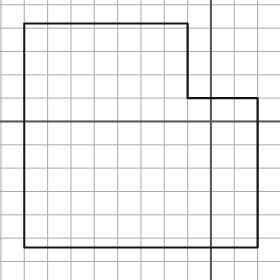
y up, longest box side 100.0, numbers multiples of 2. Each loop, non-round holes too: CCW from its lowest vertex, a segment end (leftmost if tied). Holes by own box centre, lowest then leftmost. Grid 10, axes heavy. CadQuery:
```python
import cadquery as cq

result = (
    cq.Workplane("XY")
    .moveTo(-80.0, -54.0)
    .lineTo(20.0, -54.0)
    .lineTo(20.0, 10.0)
    .lineTo(-10.0, 10.0)
    .lineTo(-10.0, 42.0)
    .lineTo(-80.0, 42.0)
    .close()
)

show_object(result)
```